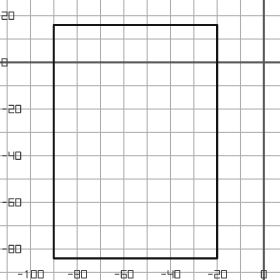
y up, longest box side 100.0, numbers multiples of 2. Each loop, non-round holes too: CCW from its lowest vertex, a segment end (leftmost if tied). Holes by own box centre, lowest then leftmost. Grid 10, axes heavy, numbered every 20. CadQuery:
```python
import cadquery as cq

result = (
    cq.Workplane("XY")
    .moveTo(-90.0, -84.0)
    .lineTo(-20.0, -84.0)
    .lineTo(-20.0, 16.0)
    .lineTo(-90.0, 16.0)
    .close()
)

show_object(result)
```